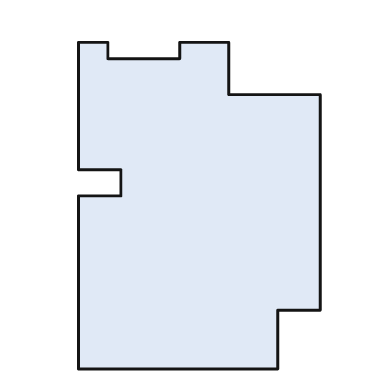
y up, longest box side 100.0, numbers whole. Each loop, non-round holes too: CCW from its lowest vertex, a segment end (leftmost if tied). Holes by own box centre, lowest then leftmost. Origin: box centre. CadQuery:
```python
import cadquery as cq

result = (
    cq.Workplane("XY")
    .moveTo(-37.0, -50.0)
    .lineTo(24.0, -50.0)
    .lineTo(24.0, -32.0)
    .lineTo(37.0, -32.0)
    .lineTo(37.0, 34.0)
    .lineTo(9.0, 34.0)
    .lineTo(9.0, 50.0)
    .lineTo(-6.0, 50.0)
    .lineTo(-6.0, 45.0)
    .lineTo(-28.0, 45.0)
    .lineTo(-28.0, 50.0)
    .lineTo(-37.0, 50.0)
    .lineTo(-37.0, 11.0)
    .lineTo(-24.0, 11.0)
    .lineTo(-24.0, 3.0)
    .lineTo(-37.0, 3.0)
    .close()
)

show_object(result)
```